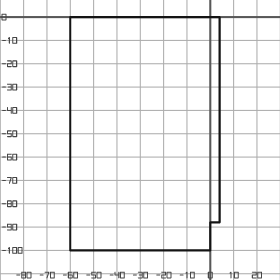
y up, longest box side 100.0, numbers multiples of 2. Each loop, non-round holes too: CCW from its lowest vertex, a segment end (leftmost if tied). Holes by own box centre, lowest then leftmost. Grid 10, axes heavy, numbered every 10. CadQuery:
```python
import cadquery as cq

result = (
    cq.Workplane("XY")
    .moveTo(-60.0, -100.0)
    .lineTo(0.0, -100.0)
    .lineTo(0.0, -88.0)
    .lineTo(4.0, -88.0)
    .lineTo(4.0, 0.0)
    .lineTo(-60.0, 0.0)
    .close()
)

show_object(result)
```